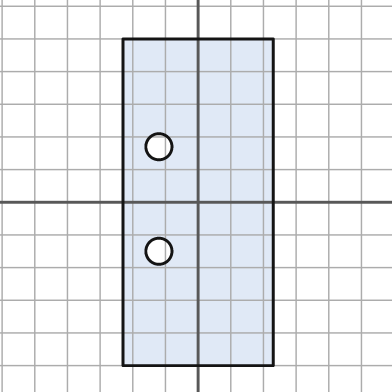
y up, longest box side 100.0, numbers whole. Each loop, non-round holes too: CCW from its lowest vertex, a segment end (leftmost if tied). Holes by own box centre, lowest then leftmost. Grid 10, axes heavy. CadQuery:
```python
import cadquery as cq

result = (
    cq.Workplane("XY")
    .moveTo(-23.0, -50.0)
    .lineTo(23.0, -50.0)
    .lineTo(23.0, 50.0)
    .lineTo(-23.0, 50.0)
    .close()
    .moveTo(-12.0, -15.0)
    .circle(4.0)
    .moveTo(-12.0, 17.0)
    .circle(4.0)
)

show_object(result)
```